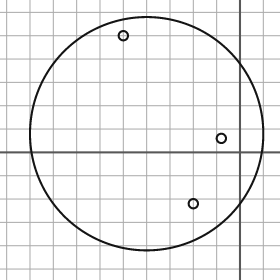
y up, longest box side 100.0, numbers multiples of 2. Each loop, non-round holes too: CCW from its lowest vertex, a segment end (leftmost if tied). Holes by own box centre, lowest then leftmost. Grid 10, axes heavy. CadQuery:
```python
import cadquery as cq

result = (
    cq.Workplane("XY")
    .moveTo(-40.0, 8.0)
    .circle(50.0)
    .moveTo(-20.0, -22.0)
    .circle(2.0)
    .moveTo(-8.0, 6.0)
    .circle(2.0)
    .moveTo(-50.0, 50.0)
    .circle(2.0)
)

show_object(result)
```